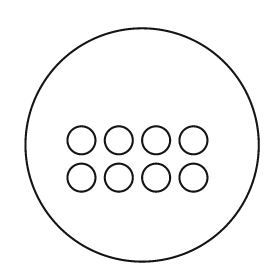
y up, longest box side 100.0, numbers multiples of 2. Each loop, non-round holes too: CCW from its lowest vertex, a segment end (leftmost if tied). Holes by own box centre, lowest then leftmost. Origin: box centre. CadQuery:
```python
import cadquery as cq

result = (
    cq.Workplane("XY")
    .moveTo(0.0, 0.0)
    .circle(50.0)
    .moveTo(-26.0, -14.0)
    .circle(6.0)
    .moveTo(-10.0, -14.0)
    .circle(6.0)
    .moveTo(6.0, -14.0)
    .circle(6.0)
    .moveTo(22.0, -14.0)
    .circle(6.0)
    .moveTo(-26.0, 2.0)
    .circle(6.0)
    .moveTo(-10.0, 2.0)
    .circle(6.0)
    .moveTo(6.0, 2.0)
    .circle(6.0)
    .moveTo(22.0, 2.0)
    .circle(6.0)
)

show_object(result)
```